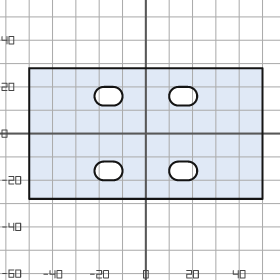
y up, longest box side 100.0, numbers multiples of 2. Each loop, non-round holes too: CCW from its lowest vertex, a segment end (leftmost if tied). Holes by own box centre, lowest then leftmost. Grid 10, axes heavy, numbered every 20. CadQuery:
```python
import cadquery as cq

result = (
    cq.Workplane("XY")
    .moveTo(-50.0, -28.0)
    .lineTo(50.0, -28.0)
    .lineTo(50.0, 28.0)
    .lineTo(-50.0, 28.0)
    .close()
    .moveTo(-18.0, -20.0)
    .lineTo(-14.0, -20.0)
    .threePointArc((-10.0, -16.0), (-14.0, -12.0))
    .lineTo(-18.0, -12.0)
    .threePointArc((-22.0, -16.0), (-18.0, -20.0))
    .close()
    .moveTo(14.0, -20.0)
    .lineTo(18.0, -20.0)
    .threePointArc((22.0, -16.0), (18.0, -12.0))
    .lineTo(14.0, -12.0)
    .threePointArc((10.0, -16.0), (14.0, -20.0))
    .close()
    .moveTo(-18.0, 12.0)
    .lineTo(-14.0, 12.0)
    .threePointArc((-10.0, 16.0), (-14.0, 20.0))
    .lineTo(-18.0, 20.0)
    .threePointArc((-22.0, 16.0), (-18.0, 12.0))
    .close()
    .moveTo(14.0, 12.0)
    .lineTo(18.0, 12.0)
    .threePointArc((22.0, 16.0), (18.0, 20.0))
    .lineTo(14.0, 20.0)
    .threePointArc((10.0, 16.0), (14.0, 12.0))
    .close()
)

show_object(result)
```